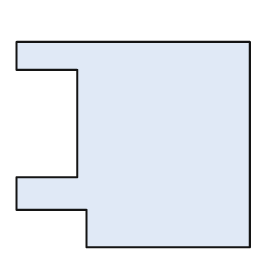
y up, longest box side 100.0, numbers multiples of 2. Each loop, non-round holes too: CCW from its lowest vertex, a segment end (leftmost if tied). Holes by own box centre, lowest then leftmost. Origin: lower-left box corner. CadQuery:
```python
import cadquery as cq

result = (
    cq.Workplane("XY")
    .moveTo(30.0, 0.0)
    .lineTo(100.0, 0.0)
    .lineTo(100.0, 88.0)
    .lineTo(0.0, 88.0)
    .lineTo(0.0, 76.0)
    .lineTo(26.0, 76.0)
    .lineTo(26.0, 30.0)
    .lineTo(0.0, 30.0)
    .lineTo(0.0, 16.0)
    .lineTo(30.0, 16.0)
    .close()
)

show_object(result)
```